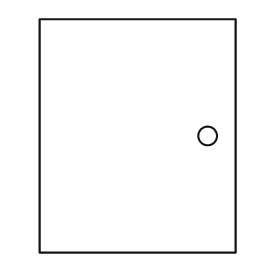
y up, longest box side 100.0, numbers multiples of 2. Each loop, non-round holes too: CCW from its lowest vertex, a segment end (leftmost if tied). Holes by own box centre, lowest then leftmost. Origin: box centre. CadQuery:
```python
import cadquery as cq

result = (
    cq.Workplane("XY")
    .moveTo(-42.0, -50.0)
    .lineTo(42.0, -50.0)
    .lineTo(42.0, 50.0)
    .lineTo(-42.0, 50.0)
    .close()
    .moveTo(30.0, 0.0)
    .circle(4.0)
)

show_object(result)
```